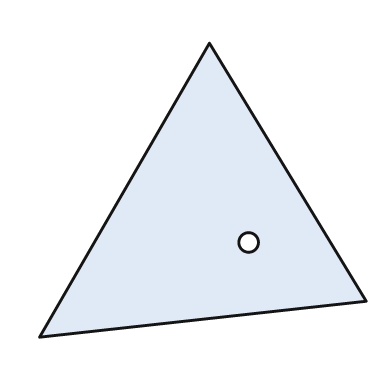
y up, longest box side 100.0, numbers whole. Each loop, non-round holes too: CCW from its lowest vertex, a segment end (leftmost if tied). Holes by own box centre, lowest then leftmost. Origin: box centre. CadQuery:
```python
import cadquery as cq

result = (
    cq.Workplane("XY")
    .moveTo(-50.0, -45.0)
    .lineTo(50.0, -34.0)
    .lineTo(2.0, 45.0)
    .close()
    .moveTo(14.0, -16.0)
    .circle(3.0)
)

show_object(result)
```